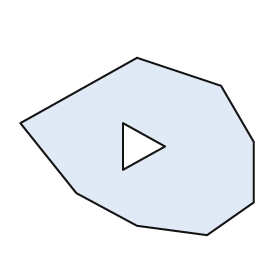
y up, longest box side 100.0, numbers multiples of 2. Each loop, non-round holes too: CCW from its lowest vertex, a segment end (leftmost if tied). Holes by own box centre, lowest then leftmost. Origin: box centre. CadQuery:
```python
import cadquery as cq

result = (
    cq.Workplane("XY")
    .moveTo(30.0, -38.0)
    .lineTo(50.0, -24.0)
    .lineTo(50.0, 2.0)
    .lineTo(36.0, 26.0)
    .lineTo(0.0, 38.0)
    .lineTo(-50.0, 10.0)
    .lineTo(-26.0, -20.0)
    .lineTo(0.0, -34.0)
    .close()
    .moveTo(-6.0, -10.0)
    .lineTo(12.0, 0.0)
    .lineTo(-6.0, 10.0)
    .close()
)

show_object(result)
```